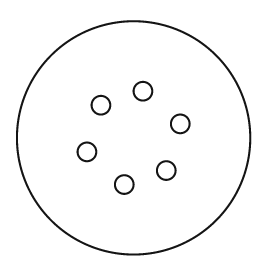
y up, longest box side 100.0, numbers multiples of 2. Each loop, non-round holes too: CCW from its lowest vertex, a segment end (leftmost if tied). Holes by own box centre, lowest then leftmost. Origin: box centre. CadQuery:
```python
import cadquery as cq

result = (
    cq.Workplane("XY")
    .moveTo(0.0, 0.0)
    .circle(50.0)
    .moveTo(-4.0, -20.0)
    .circle(4.0)
    .moveTo(14.0, -14.0)
    .circle(4.0)
    .moveTo(-20.0, -6.0)
    .circle(4.0)
    .moveTo(20.0, 6.0)
    .circle(4.0)
    .moveTo(-14.0, 14.0)
    .circle(4.0)
    .moveTo(4.0, 20.0)
    .circle(4.0)
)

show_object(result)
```